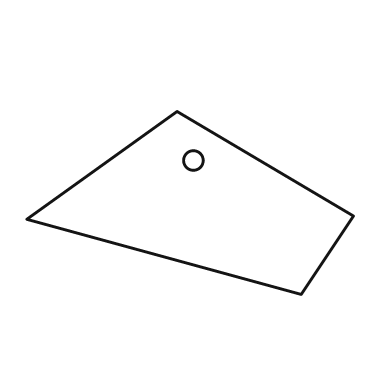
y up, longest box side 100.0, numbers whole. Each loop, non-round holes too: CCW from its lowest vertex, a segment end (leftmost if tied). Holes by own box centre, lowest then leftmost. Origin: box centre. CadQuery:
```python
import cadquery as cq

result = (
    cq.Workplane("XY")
    .moveTo(34.0, -28.0)
    .lineTo(50.0, -4.0)
    .lineTo(-4.0, 28.0)
    .lineTo(-50.0, -5.0)
    .close()
    .moveTo(1.0, 13.0)
    .circle(3.0)
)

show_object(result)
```